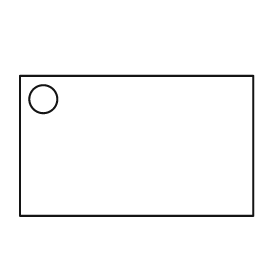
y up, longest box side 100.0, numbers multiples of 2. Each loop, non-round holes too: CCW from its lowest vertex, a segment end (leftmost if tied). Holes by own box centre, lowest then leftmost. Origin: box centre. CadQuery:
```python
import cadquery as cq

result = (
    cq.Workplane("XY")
    .moveTo(-50.0, -30.0)
    .lineTo(50.0, -30.0)
    .lineTo(50.0, 30.0)
    .lineTo(-50.0, 30.0)
    .close()
    .moveTo(-40.0, 20.0)
    .circle(6.0)
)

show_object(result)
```